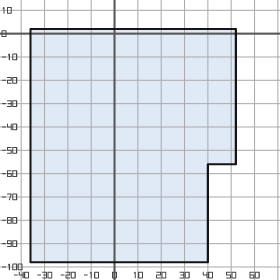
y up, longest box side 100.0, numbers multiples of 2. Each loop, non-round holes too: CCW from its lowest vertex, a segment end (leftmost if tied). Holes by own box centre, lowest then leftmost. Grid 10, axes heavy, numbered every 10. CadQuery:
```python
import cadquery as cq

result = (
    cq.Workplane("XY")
    .moveTo(-36.0, -98.0)
    .lineTo(40.0, -98.0)
    .lineTo(40.0, -56.0)
    .lineTo(52.0, -56.0)
    .lineTo(52.0, 2.0)
    .lineTo(-36.0, 2.0)
    .close()
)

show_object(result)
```